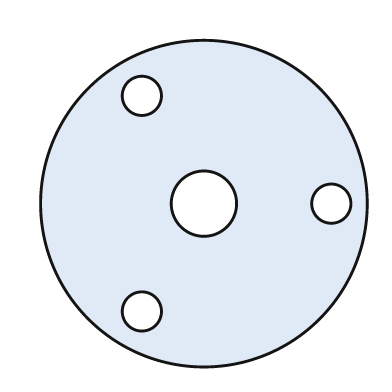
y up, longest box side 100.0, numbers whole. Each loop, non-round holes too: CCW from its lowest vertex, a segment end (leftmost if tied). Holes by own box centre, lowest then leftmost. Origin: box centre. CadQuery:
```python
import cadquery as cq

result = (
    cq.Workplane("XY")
    .moveTo(0.0, 0.0)
    .circle(50.0)
    .moveTo(-19.0, -33.0)
    .circle(6.0)
    .moveTo(0.0, 0.0)
    .circle(10.0)
    .moveTo(39.0, 0.0)
    .circle(6.0)
    .moveTo(-19.0, 33.0)
    .circle(6.0)
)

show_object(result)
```